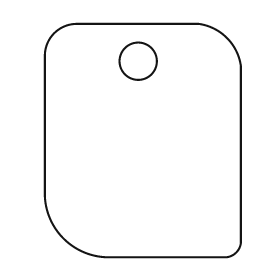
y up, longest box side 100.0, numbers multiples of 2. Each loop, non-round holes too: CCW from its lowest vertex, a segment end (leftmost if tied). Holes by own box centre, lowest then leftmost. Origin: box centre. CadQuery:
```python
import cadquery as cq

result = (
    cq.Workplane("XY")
    .moveTo(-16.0, -50.0)
    .lineTo(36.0, -50.0)
    .threePointArc((40.0, -48.0), (42.0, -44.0))
    .lineTo(42.0, 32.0)
    .threePointArc((36.0, 44.0), (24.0, 50.0))
    .lineTo(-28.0, 50.0)
    .threePointArc((-38.0, 46.0), (-42.0, 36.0))
    .lineTo(-42.0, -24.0)
    .threePointArc((-34.0, -42.0), (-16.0, -50.0))
    .close()
    .moveTo(-2.0, 34.0)
    .circle(8.0)
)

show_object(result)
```